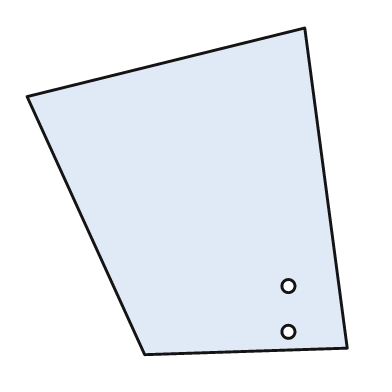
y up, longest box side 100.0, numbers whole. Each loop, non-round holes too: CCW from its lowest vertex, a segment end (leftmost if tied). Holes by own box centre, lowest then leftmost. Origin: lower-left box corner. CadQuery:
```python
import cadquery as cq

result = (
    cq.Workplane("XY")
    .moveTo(36.0, 0.0)
    .lineTo(98.0, 2.0)
    .lineTo(85.0, 100.0)
    .lineTo(0.0, 79.0)
    .close()
    .moveTo(80.0, 7.0)
    .circle(2.0)
    .moveTo(80.0, 21.0)
    .circle(2.0)
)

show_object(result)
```